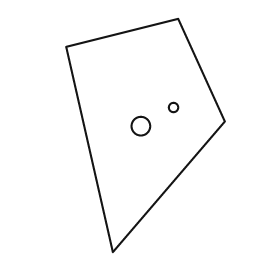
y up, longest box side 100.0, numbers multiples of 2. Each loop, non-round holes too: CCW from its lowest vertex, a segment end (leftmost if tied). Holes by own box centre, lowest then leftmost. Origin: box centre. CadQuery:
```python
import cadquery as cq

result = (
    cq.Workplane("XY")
    .moveTo(-14.0, -50.0)
    .lineTo(34.0, 6.0)
    .lineTo(14.0, 50.0)
    .lineTo(-34.0, 38.0)
    .close()
    .moveTo(-2.0, 4.0)
    .circle(4.0)
    .moveTo(12.0, 12.0)
    .circle(2.0)
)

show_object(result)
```